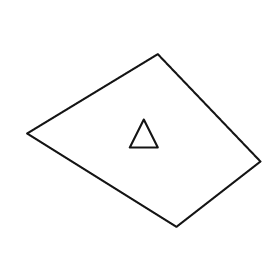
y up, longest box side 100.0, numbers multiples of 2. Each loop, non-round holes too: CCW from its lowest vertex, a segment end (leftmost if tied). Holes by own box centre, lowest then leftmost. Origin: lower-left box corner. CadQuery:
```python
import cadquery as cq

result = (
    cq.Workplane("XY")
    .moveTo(64.0, 0.0)
    .lineTo(100.0, 28.0)
    .lineTo(56.0, 74.0)
    .lineTo(0.0, 40.0)
    .close()
    .moveTo(44.0, 34.0)
    .lineTo(56.0, 34.0)
    .lineTo(50.0, 46.0)
    .close()
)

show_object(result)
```